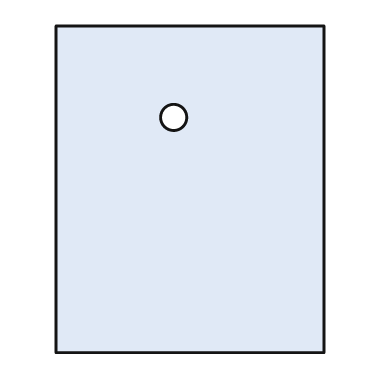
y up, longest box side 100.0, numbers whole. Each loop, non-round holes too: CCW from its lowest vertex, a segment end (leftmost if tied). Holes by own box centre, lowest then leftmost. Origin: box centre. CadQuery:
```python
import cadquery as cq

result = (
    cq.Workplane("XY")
    .moveTo(-41.0, -50.0)
    .lineTo(41.0, -50.0)
    .lineTo(41.0, 50.0)
    .lineTo(-41.0, 50.0)
    .close()
    .moveTo(-5.0, 22.0)
    .circle(4.0)
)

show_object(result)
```